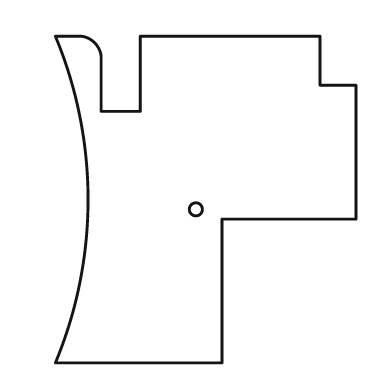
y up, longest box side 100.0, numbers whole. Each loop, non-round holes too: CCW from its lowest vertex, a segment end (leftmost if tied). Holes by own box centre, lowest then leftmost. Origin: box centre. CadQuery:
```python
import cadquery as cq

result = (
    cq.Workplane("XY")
    .moveTo(-46.0, -50.0)
    .lineTo(5.0, -50.0)
    .lineTo(5.0, -6.0)
    .lineTo(46.0, -6.0)
    .lineTo(46.0, 35.0)
    .lineTo(35.0, 35.0)
    .lineTo(35.0, 50.0)
    .lineTo(-20.0, 50.0)
    .lineTo(-20.0, 27.0)
    .lineTo(-32.0, 27.0)
    .lineTo(-32.0, 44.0)
    .threePointArc((-34.0, 48.0), (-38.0, 50.0))
    .lineTo(-46.0, 50.0)
    .threePointArc((-36.0, 0.0), (-46.0, -50.0))
    .close()
    .moveTo(-3.0, -3.0)
    .circle(2.0)
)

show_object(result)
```